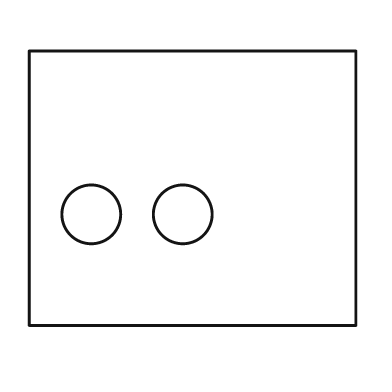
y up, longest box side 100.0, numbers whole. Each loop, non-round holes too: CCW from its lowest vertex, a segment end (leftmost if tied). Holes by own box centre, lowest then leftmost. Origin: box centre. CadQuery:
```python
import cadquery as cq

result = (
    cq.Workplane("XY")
    .moveTo(-50.0, -42.0)
    .lineTo(50.0, -42.0)
    .lineTo(50.0, 42.0)
    .lineTo(-50.0, 42.0)
    .close()
    .moveTo(-31.0, -8.0)
    .circle(9.0)
    .moveTo(-3.0, -8.0)
    .circle(9.0)
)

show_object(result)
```